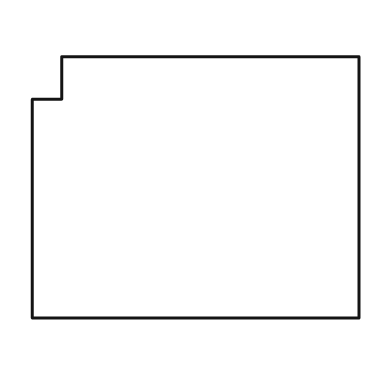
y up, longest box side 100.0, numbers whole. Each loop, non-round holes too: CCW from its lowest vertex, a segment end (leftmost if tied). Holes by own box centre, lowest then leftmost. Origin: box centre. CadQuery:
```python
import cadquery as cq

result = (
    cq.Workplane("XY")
    .moveTo(-50.0, -40.0)
    .lineTo(50.0, -40.0)
    .lineTo(50.0, 40.0)
    .lineTo(-41.0, 40.0)
    .lineTo(-41.0, 27.0)
    .lineTo(-50.0, 27.0)
    .close()
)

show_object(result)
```